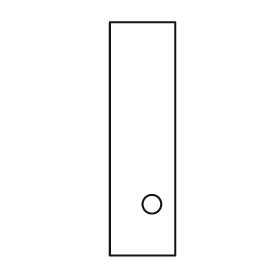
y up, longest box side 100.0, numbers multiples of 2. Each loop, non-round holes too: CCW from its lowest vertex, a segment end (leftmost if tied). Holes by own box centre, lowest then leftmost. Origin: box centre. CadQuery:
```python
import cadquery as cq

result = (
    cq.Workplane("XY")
    .moveTo(-14.0, -50.0)
    .lineTo(14.0, -50.0)
    .lineTo(14.0, 50.0)
    .lineTo(-14.0, 50.0)
    .close()
    .moveTo(4.0, -28.0)
    .circle(4.0)
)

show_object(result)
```